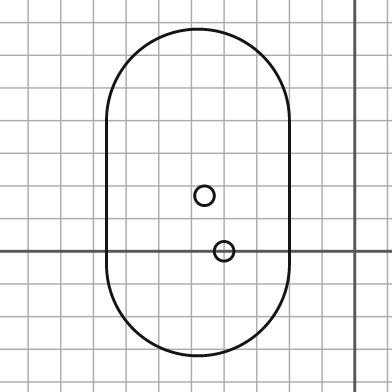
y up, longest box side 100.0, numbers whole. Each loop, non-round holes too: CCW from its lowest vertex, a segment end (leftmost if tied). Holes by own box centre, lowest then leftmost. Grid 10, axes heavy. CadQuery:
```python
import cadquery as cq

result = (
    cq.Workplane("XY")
    .moveTo(-76.0, -4.0)
    .threePointArc((-48.0, -32.0), (-20.0, -4.0))
    .lineTo(-20.0, 40.0)
    .threePointArc((-48.0, 68.0), (-76.0, 40.0))
    .close()
    .moveTo(-40.0, 0.0)
    .circle(3.0)
    .moveTo(-46.0, 17.0)
    .circle(3.0)
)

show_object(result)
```